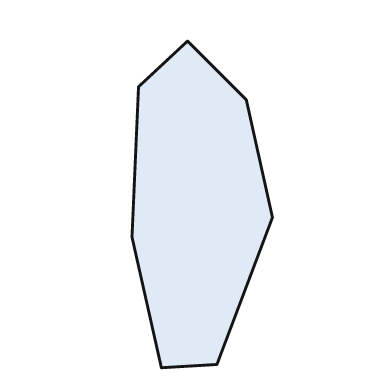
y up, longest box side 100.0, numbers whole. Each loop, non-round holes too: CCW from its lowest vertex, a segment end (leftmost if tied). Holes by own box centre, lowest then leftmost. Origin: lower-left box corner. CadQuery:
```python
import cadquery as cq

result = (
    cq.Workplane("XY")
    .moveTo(9.0, 0.0)
    .lineTo(26.0, 1.0)
    .lineTo(43.0, 46.0)
    .lineTo(35.0, 82.0)
    .lineTo(17.0, 100.0)
    .lineTo(2.0, 86.0)
    .lineTo(0.0, 40.0)
    .close()
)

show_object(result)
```